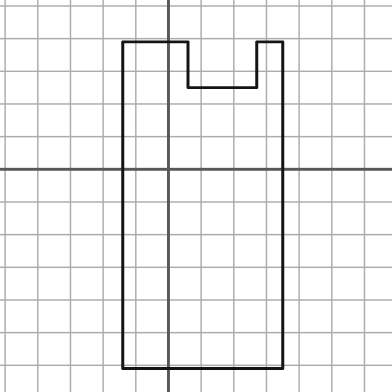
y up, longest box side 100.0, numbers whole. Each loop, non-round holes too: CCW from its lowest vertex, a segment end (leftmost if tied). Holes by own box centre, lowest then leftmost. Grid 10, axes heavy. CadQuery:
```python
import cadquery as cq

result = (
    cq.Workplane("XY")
    .moveTo(-14.0, -61.0)
    .lineTo(35.0, -61.0)
    .lineTo(35.0, 39.0)
    .lineTo(27.0, 39.0)
    .lineTo(27.0, 25.0)
    .lineTo(6.0, 25.0)
    .lineTo(6.0, 39.0)
    .lineTo(-14.0, 39.0)
    .close()
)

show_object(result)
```